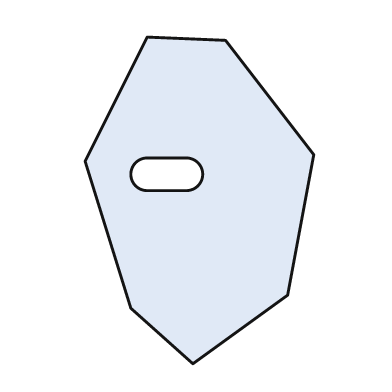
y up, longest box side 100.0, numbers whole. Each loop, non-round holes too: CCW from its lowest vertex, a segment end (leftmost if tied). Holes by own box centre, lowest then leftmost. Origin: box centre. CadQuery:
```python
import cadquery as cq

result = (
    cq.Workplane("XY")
    .moveTo(-2.0, -50.0)
    .lineTo(27.0, -29.0)
    .lineTo(35.0, 14.0)
    .lineTo(8.0, 49.0)
    .lineTo(-16.0, 50.0)
    .lineTo(-35.0, 12.0)
    .lineTo(-21.0, -33.0)
    .close()
    .moveTo(-16.0, 3.0)
    .lineTo(-4.0, 3.0)
    .threePointArc((1.0, 8.0), (-4.0, 13.0))
    .lineTo(-16.0, 13.0)
    .threePointArc((-21.0, 8.0), (-16.0, 3.0))
    .close()
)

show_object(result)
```